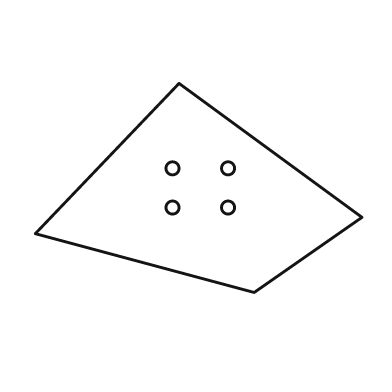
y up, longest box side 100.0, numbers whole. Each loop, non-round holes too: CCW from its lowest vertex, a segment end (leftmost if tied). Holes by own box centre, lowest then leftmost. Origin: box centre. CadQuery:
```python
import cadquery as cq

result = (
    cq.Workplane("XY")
    .moveTo(17.0, -32.0)
    .lineTo(50.0, -9.0)
    .lineTo(-6.0, 32.0)
    .lineTo(-50.0, -14.0)
    .close()
    .moveTo(-8.0, -6.0)
    .circle(2.0)
    .moveTo(9.0, -6.0)
    .circle(2.0)
    .moveTo(-8.0, 6.0)
    .circle(2.0)
    .moveTo(9.0, 6.0)
    .circle(2.0)
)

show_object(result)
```